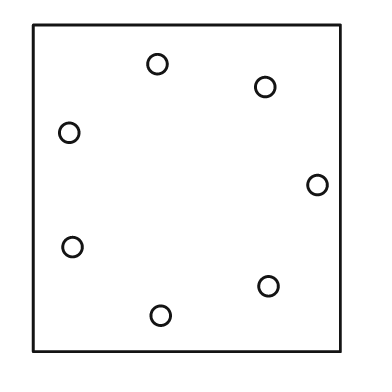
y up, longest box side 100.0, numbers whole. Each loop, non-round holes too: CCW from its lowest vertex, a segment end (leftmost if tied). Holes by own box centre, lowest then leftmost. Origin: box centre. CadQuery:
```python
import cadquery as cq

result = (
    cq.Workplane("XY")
    .moveTo(-47.0, -50.0)
    .lineTo(47.0, -50.0)
    .lineTo(47.0, 50.0)
    .lineTo(-47.0, 50.0)
    .close()
    .moveTo(-8.0, -39.0)
    .circle(3.0)
    .moveTo(25.0, -30.0)
    .circle(3.0)
    .moveTo(-35.0, -18.0)
    .circle(3.0)
    .moveTo(40.0, 1.0)
    .circle(3.0)
    .moveTo(-36.0, 17.0)
    .circle(3.0)
    .moveTo(24.0, 31.0)
    .circle(3.0)
    .moveTo(-9.0, 38.0)
    .circle(3.0)
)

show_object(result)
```